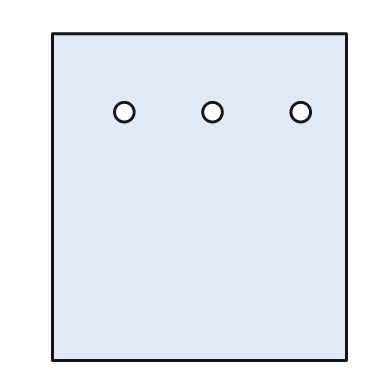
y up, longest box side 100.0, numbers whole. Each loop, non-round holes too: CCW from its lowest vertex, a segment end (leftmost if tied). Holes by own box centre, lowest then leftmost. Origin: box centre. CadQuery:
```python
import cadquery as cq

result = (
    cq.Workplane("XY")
    .moveTo(-45.0, -50.0)
    .lineTo(45.0, -50.0)
    .lineTo(45.0, 50.0)
    .lineTo(-45.0, 50.0)
    .close()
    .moveTo(-23.0, 26.0)
    .circle(3.0)
    .moveTo(4.0, 26.0)
    .circle(3.0)
    .moveTo(31.0, 26.0)
    .circle(3.0)
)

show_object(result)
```